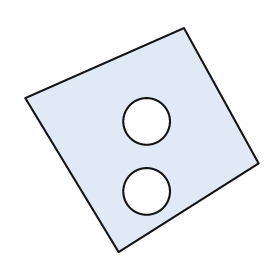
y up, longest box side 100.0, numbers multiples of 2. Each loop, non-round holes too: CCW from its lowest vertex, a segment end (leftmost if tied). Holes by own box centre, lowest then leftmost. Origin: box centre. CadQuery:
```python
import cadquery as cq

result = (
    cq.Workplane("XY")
    .moveTo(-10.0, -48.0)
    .lineTo(50.0, -10.0)
    .lineTo(18.0, 48.0)
    .lineTo(-50.0, 18.0)
    .close()
    .moveTo(2.0, -22.0)
    .circle(10.0)
    .moveTo(2.0, 8.0)
    .circle(10.0)
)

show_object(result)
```